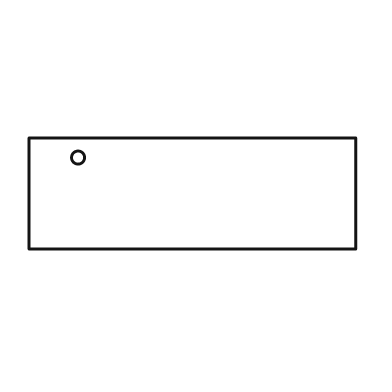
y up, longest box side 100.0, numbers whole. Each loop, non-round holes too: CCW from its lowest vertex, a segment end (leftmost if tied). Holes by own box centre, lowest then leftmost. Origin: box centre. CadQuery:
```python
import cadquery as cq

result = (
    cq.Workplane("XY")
    .moveTo(-50.0, -17.0)
    .lineTo(50.0, -17.0)
    .lineTo(50.0, 17.0)
    .lineTo(-50.0, 17.0)
    .close()
    .moveTo(-35.0, 11.0)
    .circle(2.0)
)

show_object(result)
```